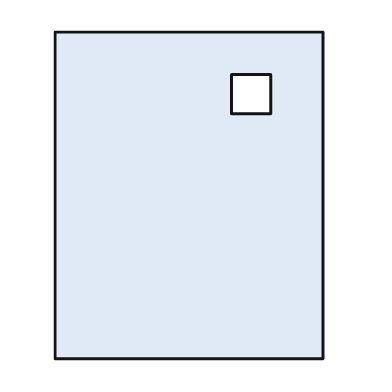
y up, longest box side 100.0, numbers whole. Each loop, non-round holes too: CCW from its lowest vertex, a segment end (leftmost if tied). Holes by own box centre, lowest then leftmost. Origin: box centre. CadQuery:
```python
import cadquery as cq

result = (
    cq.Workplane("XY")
    .moveTo(-41.0, -50.0)
    .lineTo(41.0, -50.0)
    .lineTo(41.0, 50.0)
    .lineTo(-41.0, 50.0)
    .close()
    .moveTo(13.0, 25.0)
    .lineTo(25.0, 25.0)
    .lineTo(25.0, 37.0)
    .lineTo(13.0, 37.0)
    .close()
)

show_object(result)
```